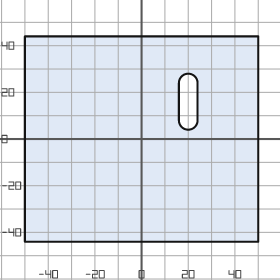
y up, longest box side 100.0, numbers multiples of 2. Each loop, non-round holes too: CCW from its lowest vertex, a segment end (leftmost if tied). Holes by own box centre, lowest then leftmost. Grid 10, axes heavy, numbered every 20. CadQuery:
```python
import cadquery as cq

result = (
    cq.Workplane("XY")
    .moveTo(-50.0, -44.0)
    .lineTo(50.0, -44.0)
    .lineTo(50.0, 44.0)
    .lineTo(-50.0, 44.0)
    .close()
    .moveTo(16.0, 8.0)
    .threePointArc((20.0, 4.0), (24.0, 8.0))
    .lineTo(24.0, 24.0)
    .threePointArc((20.0, 28.0), (16.0, 24.0))
    .close()
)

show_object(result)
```